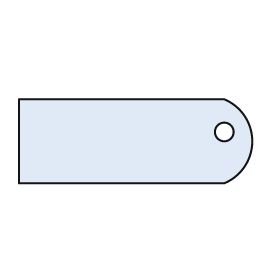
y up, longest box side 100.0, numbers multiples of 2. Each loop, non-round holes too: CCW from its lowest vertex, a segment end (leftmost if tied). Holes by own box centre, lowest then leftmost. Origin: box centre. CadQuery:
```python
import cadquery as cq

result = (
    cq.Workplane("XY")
    .moveTo(-50.0, -18.0)
    .lineTo(38.0, -18.0)
    .threePointArc((50.0, 0.0), (38.0, 18.0))
    .lineTo(-50.0, 18.0)
    .close()
    .moveTo(38.0, 4.0)
    .circle(4.0)
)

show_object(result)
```